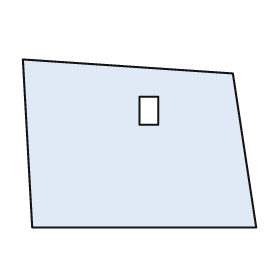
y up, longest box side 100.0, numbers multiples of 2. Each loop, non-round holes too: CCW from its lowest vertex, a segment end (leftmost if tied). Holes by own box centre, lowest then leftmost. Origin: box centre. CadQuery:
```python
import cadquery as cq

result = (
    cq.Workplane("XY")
    .moveTo(-46.0, -36.0)
    .lineTo(50.0, -36.0)
    .lineTo(40.0, 30.0)
    .lineTo(-50.0, 36.0)
    .close()
    .moveTo(0.0, 8.0)
    .lineTo(8.0, 8.0)
    .lineTo(8.0, 20.0)
    .lineTo(0.0, 20.0)
    .close()
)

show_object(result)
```